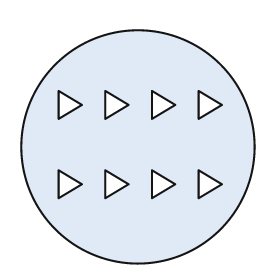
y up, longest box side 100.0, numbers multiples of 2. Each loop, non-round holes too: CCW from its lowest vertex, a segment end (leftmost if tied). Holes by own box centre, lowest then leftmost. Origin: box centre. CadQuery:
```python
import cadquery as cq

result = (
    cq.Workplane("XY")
    .moveTo(0.0, 0.0)
    .circle(50.0)
    .moveTo(-34.0, -22.0)
    .lineTo(-24.0, -16.0)
    .lineTo(-34.0, -10.0)
    .close()
    .moveTo(-14.0, -22.0)
    .lineTo(-4.0, -16.0)
    .lineTo(-14.0, -10.0)
    .close()
    .moveTo(6.0, -22.0)
    .lineTo(16.0, -16.0)
    .lineTo(6.0, -10.0)
    .close()
    .moveTo(26.0, -22.0)
    .lineTo(36.0, -16.0)
    .lineTo(26.0, -10.0)
    .close()
    .moveTo(-34.0, 12.0)
    .lineTo(-24.0, 18.0)
    .lineTo(-34.0, 24.0)
    .close()
    .moveTo(-14.0, 12.0)
    .lineTo(-4.0, 18.0)
    .lineTo(-14.0, 24.0)
    .close()
    .moveTo(6.0, 12.0)
    .lineTo(16.0, 18.0)
    .lineTo(6.0, 24.0)
    .close()
    .moveTo(26.0, 12.0)
    .lineTo(36.0, 18.0)
    .lineTo(26.0, 24.0)
    .close()
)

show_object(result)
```